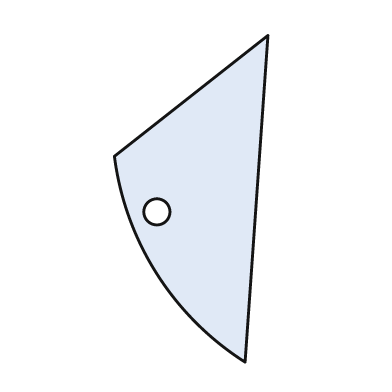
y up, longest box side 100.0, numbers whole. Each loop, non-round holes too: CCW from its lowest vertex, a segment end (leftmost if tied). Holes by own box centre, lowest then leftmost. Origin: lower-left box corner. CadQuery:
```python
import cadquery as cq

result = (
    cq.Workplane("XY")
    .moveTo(40.0, 0.0)
    .lineTo(47.0, 100.0)
    .lineTo(0.0, 63.0)
    .threePointArc((13.0, 27.0), (40.0, 0.0))
    .close()
    .moveTo(13.0, 46.0)
    .circle(4.0)
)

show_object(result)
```